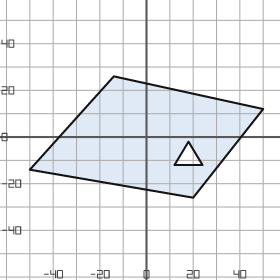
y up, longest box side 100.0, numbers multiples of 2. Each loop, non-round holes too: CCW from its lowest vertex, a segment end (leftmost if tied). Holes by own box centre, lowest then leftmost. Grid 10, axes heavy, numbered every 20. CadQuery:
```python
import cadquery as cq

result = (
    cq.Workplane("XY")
    .moveTo(20.0, -26.0)
    .lineTo(50.0, 12.0)
    .lineTo(-14.0, 26.0)
    .lineTo(-50.0, -14.0)
    .close()
    .moveTo(12.0, -12.0)
    .lineTo(24.0, -12.0)
    .lineTo(18.0, -2.0)
    .close()
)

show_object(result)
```